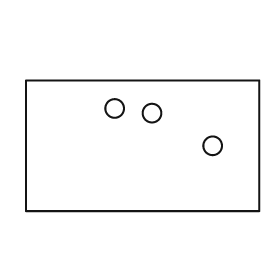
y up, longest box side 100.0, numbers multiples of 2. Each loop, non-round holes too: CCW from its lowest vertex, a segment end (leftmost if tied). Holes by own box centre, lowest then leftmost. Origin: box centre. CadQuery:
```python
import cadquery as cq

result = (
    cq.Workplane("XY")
    .moveTo(-50.0, -28.0)
    .lineTo(50.0, -28.0)
    .lineTo(50.0, 28.0)
    .lineTo(-50.0, 28.0)
    .close()
    .moveTo(30.0, 0.0)
    .circle(4.0)
    .moveTo(4.0, 14.0)
    .circle(4.0)
    .moveTo(-12.0, 16.0)
    .circle(4.0)
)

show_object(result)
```